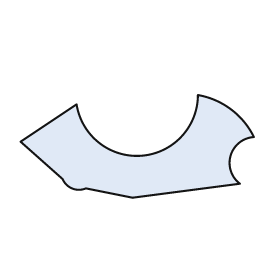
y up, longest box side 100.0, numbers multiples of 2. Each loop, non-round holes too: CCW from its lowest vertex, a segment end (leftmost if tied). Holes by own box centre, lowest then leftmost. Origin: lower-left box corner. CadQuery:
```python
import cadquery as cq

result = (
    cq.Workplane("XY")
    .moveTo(48.0, 0.0)
    .lineTo(94.0, 6.0)
    .threePointArc((90.0, 18.0), (100.0, 26.0))
    .threePointArc((90.0, 38.0), (76.0, 44.0))
    .threePointArc((52.0, 18.0), (24.0, 40.0))
    .lineTo(0.0, 24.0)
    .lineTo(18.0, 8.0)
    .threePointArc((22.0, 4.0), (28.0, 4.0))
    .close()
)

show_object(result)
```